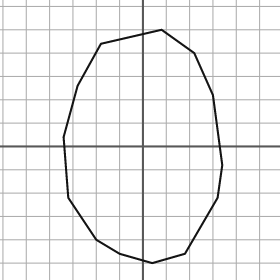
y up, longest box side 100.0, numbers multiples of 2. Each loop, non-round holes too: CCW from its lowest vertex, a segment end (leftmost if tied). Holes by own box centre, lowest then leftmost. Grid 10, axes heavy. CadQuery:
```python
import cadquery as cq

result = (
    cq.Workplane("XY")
    .moveTo(4.0, -50.0)
    .lineTo(18.0, -46.0)
    .lineTo(32.0, -22.0)
    .lineTo(34.0, -8.0)
    .lineTo(30.0, 22.0)
    .lineTo(22.0, 40.0)
    .lineTo(8.0, 50.0)
    .lineTo(-18.0, 44.0)
    .lineTo(-28.0, 26.0)
    .lineTo(-34.0, 4.0)
    .lineTo(-32.0, -22.0)
    .lineTo(-20.0, -40.0)
    .lineTo(-10.0, -46.0)
    .close()
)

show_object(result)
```